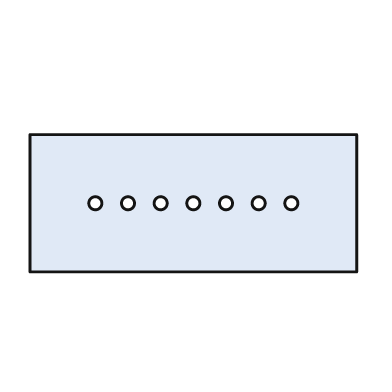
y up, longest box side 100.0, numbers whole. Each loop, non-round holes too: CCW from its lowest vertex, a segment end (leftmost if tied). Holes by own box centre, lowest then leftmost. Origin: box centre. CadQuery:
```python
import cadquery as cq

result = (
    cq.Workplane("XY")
    .moveTo(-50.0, -21.0)
    .lineTo(50.0, -21.0)
    .lineTo(50.0, 21.0)
    .lineTo(-50.0, 21.0)
    .close()
    .moveTo(-30.0, 0.0)
    .circle(2.0)
    .moveTo(-20.0, 0.0)
    .circle(2.0)
    .moveTo(-10.0, 0.0)
    .circle(2.0)
    .moveTo(0.0, 0.0)
    .circle(2.0)
    .moveTo(10.0, 0.0)
    .circle(2.0)
    .moveTo(20.0, 0.0)
    .circle(2.0)
    .moveTo(30.0, 0.0)
    .circle(2.0)
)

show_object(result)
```